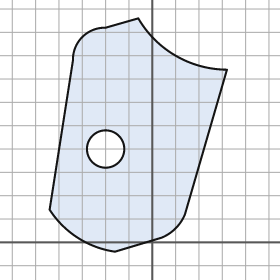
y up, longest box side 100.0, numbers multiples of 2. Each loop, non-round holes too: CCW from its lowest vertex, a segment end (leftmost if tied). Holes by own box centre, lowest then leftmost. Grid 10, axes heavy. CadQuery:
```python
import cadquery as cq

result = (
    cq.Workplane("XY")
    .moveTo(-16.0, -4.0)
    .lineTo(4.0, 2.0)
    .threePointArc((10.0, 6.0), (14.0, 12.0))
    .lineTo(32.0, 74.0)
    .threePointArc((10.0, 80.0), (-6.0, 96.0))
    .lineTo(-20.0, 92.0)
    .threePointArc((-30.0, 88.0), (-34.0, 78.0))
    .lineTo(-44.0, 14.0)
    .threePointArc((-32.0, 2.0), (-16.0, -4.0))
    .close()
    .moveTo(-20.0, 40.0)
    .circle(8.0)
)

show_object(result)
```